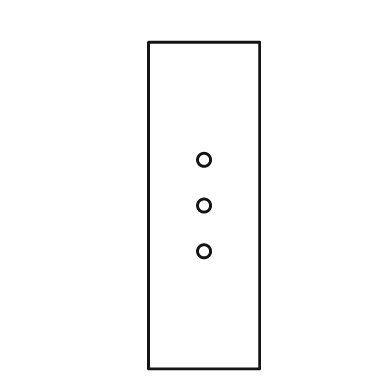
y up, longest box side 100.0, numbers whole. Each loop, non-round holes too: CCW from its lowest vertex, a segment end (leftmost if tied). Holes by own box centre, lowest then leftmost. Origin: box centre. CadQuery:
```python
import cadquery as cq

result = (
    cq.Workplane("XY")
    .moveTo(-17.0, -50.0)
    .lineTo(17.0, -50.0)
    .lineTo(17.0, 50.0)
    .lineTo(-17.0, 50.0)
    .close()
    .moveTo(0.0, -14.0)
    .circle(2.0)
    .moveTo(0.0, 0.0)
    .circle(2.0)
    .moveTo(0.0, 14.0)
    .circle(2.0)
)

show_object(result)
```